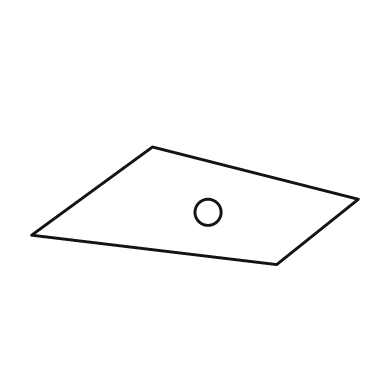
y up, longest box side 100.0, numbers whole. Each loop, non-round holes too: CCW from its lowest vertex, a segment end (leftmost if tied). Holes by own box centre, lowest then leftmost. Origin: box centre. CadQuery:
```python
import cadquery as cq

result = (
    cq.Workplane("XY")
    .moveTo(25.0, -18.0)
    .lineTo(50.0, 2.0)
    .lineTo(-13.0, 18.0)
    .lineTo(-50.0, -9.0)
    .close()
    .moveTo(4.0, -2.0)
    .circle(4.0)
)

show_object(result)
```